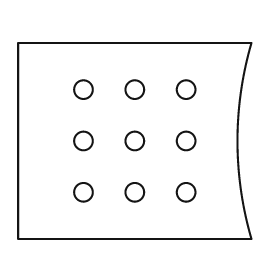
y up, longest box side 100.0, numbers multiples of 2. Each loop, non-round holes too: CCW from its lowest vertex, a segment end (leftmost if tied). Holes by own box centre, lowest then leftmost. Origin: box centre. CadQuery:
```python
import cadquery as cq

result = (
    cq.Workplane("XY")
    .moveTo(-50.0, -42.0)
    .lineTo(50.0, -42.0)
    .threePointArc((44.0, 0.0), (50.0, 42.0))
    .lineTo(-50.0, 42.0)
    .close()
    .moveTo(-22.0, -22.0)
    .circle(4.0)
    .moveTo(0.0, -22.0)
    .circle(4.0)
    .moveTo(22.0, -22.0)
    .circle(4.0)
    .moveTo(-22.0, 0.0)
    .circle(4.0)
    .moveTo(0.0, 0.0)
    .circle(4.0)
    .moveTo(22.0, 0.0)
    .circle(4.0)
    .moveTo(-22.0, 22.0)
    .circle(4.0)
    .moveTo(0.0, 22.0)
    .circle(4.0)
    .moveTo(22.0, 22.0)
    .circle(4.0)
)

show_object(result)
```